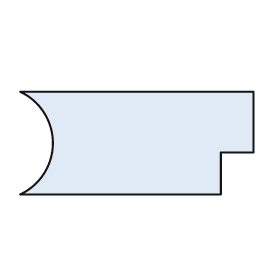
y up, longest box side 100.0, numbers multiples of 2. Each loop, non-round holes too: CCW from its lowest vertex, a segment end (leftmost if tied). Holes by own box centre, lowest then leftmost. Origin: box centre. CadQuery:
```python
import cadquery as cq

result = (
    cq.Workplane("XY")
    .moveTo(-50.0, -22.0)
    .lineTo(36.0, -22.0)
    .lineTo(36.0, -4.0)
    .lineTo(50.0, -4.0)
    .lineTo(50.0, 22.0)
    .lineTo(-50.0, 22.0)
    .threePointArc((-36.0, 0.0), (-50.0, -22.0))
    .close()
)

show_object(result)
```